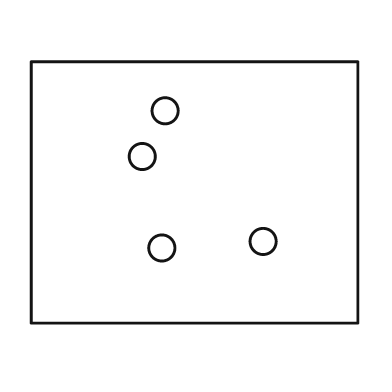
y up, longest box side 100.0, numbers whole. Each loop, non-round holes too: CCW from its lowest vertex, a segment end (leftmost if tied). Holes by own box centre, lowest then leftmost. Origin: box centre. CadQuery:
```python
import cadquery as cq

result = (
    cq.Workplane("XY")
    .moveTo(-50.0, -40.0)
    .lineTo(50.0, -40.0)
    .lineTo(50.0, 40.0)
    .lineTo(-50.0, 40.0)
    .close()
    .moveTo(-10.0, -17.0)
    .circle(4.0)
    .moveTo(21.0, -15.0)
    .circle(4.0)
    .moveTo(-16.0, 11.0)
    .circle(4.0)
    .moveTo(-9.0, 25.0)
    .circle(4.0)
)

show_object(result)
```